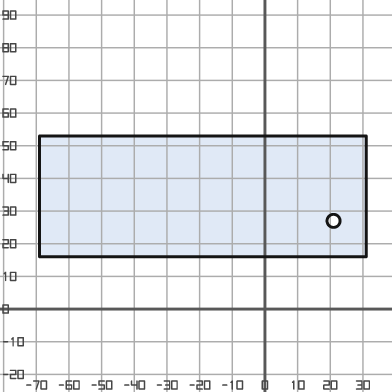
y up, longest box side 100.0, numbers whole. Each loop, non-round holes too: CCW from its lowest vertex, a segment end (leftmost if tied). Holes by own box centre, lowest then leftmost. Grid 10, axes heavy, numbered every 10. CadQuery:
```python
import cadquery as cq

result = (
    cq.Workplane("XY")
    .moveTo(-69.0, 16.0)
    .lineTo(31.0, 16.0)
    .lineTo(31.0, 53.0)
    .lineTo(-69.0, 53.0)
    .close()
    .moveTo(21.0, 27.0)
    .circle(2.0)
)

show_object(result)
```